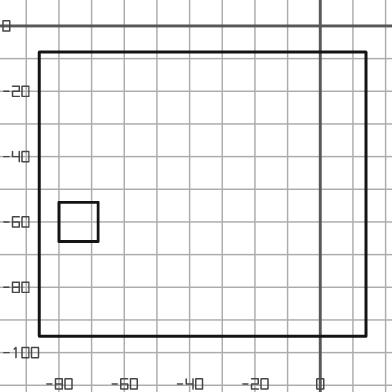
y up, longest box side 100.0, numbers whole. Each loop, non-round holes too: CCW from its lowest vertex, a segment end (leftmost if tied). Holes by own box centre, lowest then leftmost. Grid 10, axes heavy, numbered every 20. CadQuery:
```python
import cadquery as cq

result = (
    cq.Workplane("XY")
    .moveTo(-86.0, -95.0)
    .lineTo(14.0, -95.0)
    .lineTo(14.0, -8.0)
    .lineTo(-86.0, -8.0)
    .close()
    .moveTo(-80.0, -66.0)
    .lineTo(-68.0, -66.0)
    .lineTo(-68.0, -54.0)
    .lineTo(-80.0, -54.0)
    .close()
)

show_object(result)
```